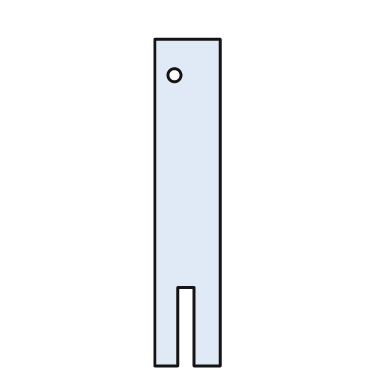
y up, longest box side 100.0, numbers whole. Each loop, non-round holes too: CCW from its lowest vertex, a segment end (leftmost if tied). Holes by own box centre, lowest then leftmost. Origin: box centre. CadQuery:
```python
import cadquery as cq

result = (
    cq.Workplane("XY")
    .moveTo(-10.0, -50.0)
    .lineTo(-3.0, -50.0)
    .lineTo(-3.0, -26.0)
    .lineTo(2.0, -26.0)
    .lineTo(2.0, -50.0)
    .lineTo(10.0, -50.0)
    .lineTo(10.0, 50.0)
    .lineTo(-10.0, 50.0)
    .close()
    .moveTo(-4.0, 39.0)
    .circle(2.0)
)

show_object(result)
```